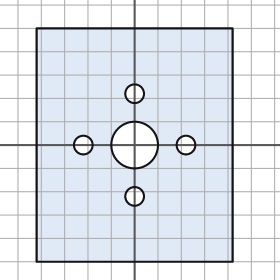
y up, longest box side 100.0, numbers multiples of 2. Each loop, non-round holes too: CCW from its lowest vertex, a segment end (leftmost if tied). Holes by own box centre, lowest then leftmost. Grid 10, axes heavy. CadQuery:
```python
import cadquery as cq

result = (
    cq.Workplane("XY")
    .moveTo(-42.0, -50.0)
    .lineTo(42.0, -50.0)
    .lineTo(42.0, 50.0)
    .lineTo(-42.0, 50.0)
    .close()
    .moveTo(0.0, -22.0)
    .circle(4.0)
    .moveTo(-22.0, 0.0)
    .circle(4.0)
    .moveTo(0.0, 0.0)
    .circle(10.0)
    .moveTo(22.0, 0.0)
    .circle(4.0)
    .moveTo(0.0, 22.0)
    .circle(4.0)
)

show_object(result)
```